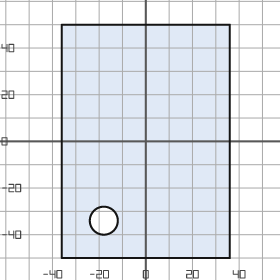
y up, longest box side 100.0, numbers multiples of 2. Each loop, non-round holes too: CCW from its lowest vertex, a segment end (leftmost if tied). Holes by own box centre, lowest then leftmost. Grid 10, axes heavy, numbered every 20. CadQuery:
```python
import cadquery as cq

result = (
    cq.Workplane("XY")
    .moveTo(-36.0, -50.0)
    .lineTo(36.0, -50.0)
    .lineTo(36.0, 50.0)
    .lineTo(-36.0, 50.0)
    .close()
    .moveTo(-18.0, -34.0)
    .circle(6.0)
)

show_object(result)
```